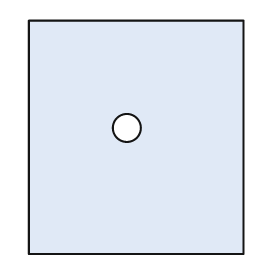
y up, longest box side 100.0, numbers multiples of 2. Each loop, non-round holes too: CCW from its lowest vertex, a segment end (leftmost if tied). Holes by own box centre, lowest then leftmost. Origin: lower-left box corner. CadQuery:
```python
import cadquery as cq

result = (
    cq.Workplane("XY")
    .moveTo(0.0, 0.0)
    .lineTo(92.0, 0.0)
    .lineTo(92.0, 100.0)
    .lineTo(0.0, 100.0)
    .close()
    .moveTo(42.0, 54.0)
    .circle(6.0)
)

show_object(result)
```